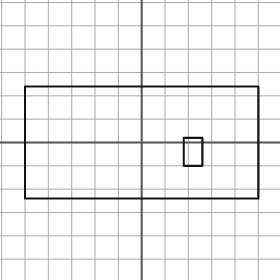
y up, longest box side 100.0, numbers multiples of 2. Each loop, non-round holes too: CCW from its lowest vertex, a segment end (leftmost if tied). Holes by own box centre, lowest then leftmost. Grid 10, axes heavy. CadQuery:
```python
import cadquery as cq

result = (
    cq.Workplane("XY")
    .moveTo(-50.0, -24.0)
    .lineTo(50.0, -24.0)
    .lineTo(50.0, 24.0)
    .lineTo(-50.0, 24.0)
    .close()
    .moveTo(18.0, -10.0)
    .lineTo(26.0, -10.0)
    .lineTo(26.0, 2.0)
    .lineTo(18.0, 2.0)
    .close()
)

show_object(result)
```